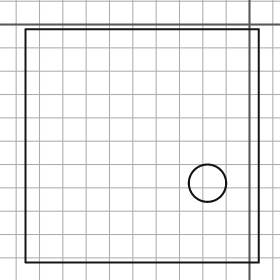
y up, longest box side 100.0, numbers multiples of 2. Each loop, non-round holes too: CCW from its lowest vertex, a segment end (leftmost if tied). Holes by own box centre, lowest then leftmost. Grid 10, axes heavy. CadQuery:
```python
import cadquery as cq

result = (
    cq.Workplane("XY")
    .moveTo(-96.0, -102.0)
    .lineTo(4.0, -102.0)
    .lineTo(4.0, -2.0)
    .lineTo(-96.0, -2.0)
    .close()
    .moveTo(-18.0, -68.0)
    .circle(8.0)
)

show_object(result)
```